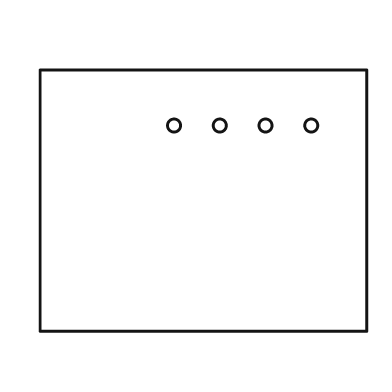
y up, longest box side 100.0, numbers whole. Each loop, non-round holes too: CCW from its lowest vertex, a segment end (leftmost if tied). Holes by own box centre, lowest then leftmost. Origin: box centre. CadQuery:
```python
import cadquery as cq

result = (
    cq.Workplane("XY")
    .moveTo(-50.0, -40.0)
    .lineTo(50.0, -40.0)
    .lineTo(50.0, 40.0)
    .lineTo(-50.0, 40.0)
    .close()
    .moveTo(-9.0, 23.0)
    .circle(2.0)
    .moveTo(5.0, 23.0)
    .circle(2.0)
    .moveTo(19.0, 23.0)
    .circle(2.0)
    .moveTo(33.0, 23.0)
    .circle(2.0)
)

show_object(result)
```